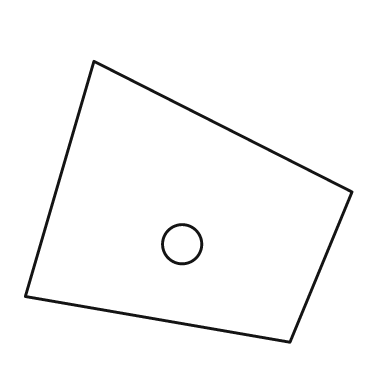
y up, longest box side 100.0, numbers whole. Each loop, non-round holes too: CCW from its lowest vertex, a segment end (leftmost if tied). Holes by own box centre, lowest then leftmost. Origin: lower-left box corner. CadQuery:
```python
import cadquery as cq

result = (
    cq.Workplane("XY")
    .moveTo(81.0, 0.0)
    .lineTo(100.0, 46.0)
    .lineTo(21.0, 86.0)
    .lineTo(0.0, 14.0)
    .close()
    .moveTo(48.0, 30.0)
    .circle(6.0)
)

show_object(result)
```